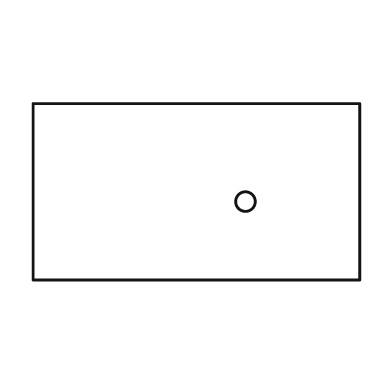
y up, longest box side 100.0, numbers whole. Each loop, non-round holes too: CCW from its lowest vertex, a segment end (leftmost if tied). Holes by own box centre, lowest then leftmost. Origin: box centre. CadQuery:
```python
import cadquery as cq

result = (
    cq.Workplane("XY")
    .moveTo(-50.0, -27.0)
    .lineTo(50.0, -27.0)
    .lineTo(50.0, 27.0)
    .lineTo(-50.0, 27.0)
    .close()
    .moveTo(15.0, -3.0)
    .circle(3.0)
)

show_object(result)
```